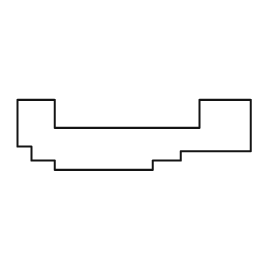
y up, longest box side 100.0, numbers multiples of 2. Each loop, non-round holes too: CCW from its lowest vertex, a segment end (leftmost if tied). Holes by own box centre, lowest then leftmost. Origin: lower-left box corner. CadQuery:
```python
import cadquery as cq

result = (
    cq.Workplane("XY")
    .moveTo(16.0, 0.0)
    .lineTo(58.0, 0.0)
    .lineTo(58.0, 4.0)
    .lineTo(70.0, 4.0)
    .lineTo(70.0, 8.0)
    .lineTo(100.0, 8.0)
    .lineTo(100.0, 30.0)
    .lineTo(78.0, 30.0)
    .lineTo(78.0, 18.0)
    .lineTo(16.0, 18.0)
    .lineTo(16.0, 30.0)
    .lineTo(0.0, 30.0)
    .lineTo(0.0, 10.0)
    .lineTo(6.0, 10.0)
    .lineTo(6.0, 4.0)
    .lineTo(16.0, 4.0)
    .close()
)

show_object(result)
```